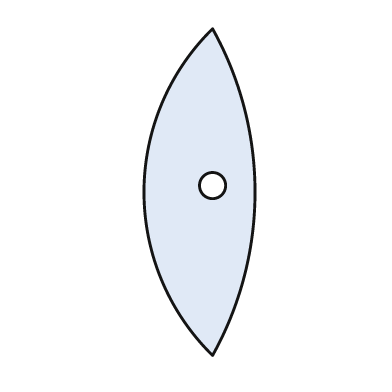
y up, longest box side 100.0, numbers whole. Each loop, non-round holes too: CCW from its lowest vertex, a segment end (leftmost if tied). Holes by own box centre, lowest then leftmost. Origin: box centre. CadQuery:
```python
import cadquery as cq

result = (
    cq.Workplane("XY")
    .moveTo(4.0, -50.0)
    .threePointArc((17.0, 0.0), (4.0, 50.0))
    .threePointArc((-17.0, 0.0), (4.0, -50.0))
    .close()
    .moveTo(4.0, 2.0)
    .circle(4.0)
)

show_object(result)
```